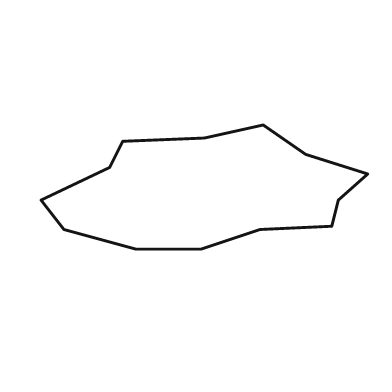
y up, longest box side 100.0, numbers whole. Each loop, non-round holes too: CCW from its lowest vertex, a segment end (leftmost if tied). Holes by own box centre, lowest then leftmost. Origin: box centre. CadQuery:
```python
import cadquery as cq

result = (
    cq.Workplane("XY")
    .moveTo(-21.0, -19.0)
    .lineTo(-1.0, -19.0)
    .lineTo(17.0, -13.0)
    .lineTo(39.0, -12.0)
    .lineTo(41.0, -4.0)
    .lineTo(50.0, 4.0)
    .lineTo(31.0, 10.0)
    .lineTo(18.0, 19.0)
    .lineTo(0.0, 15.0)
    .lineTo(-25.0, 14.0)
    .lineTo(-29.0, 6.0)
    .lineTo(-50.0, -4.0)
    .lineTo(-43.0, -13.0)
    .close()
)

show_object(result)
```